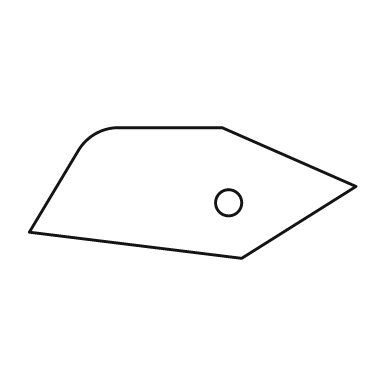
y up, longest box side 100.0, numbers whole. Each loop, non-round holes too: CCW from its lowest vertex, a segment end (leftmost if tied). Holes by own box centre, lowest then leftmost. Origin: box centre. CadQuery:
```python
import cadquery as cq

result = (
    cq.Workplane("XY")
    .moveTo(15.0, -20.0)
    .lineTo(50.0, 2.0)
    .lineTo(9.0, 20.0)
    .lineTo(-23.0, 20.0)
    .threePointArc((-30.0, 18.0), (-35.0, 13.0))
    .lineTo(-50.0, -12.0)
    .close()
    .moveTo(11.0, -3.0)
    .circle(4.0)
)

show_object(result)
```